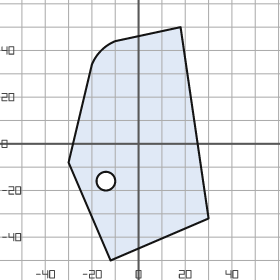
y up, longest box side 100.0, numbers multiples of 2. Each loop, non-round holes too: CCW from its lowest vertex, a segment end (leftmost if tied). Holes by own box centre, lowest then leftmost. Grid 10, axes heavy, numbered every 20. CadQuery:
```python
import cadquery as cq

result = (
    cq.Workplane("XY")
    .moveTo(-12.0, -50.0)
    .lineTo(30.0, -32.0)
    .lineTo(18.0, 50.0)
    .lineTo(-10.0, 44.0)
    .threePointArc((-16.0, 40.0), (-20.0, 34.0))
    .lineTo(-30.0, -8.0)
    .close()
    .moveTo(-14.0, -16.0)
    .circle(4.0)
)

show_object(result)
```